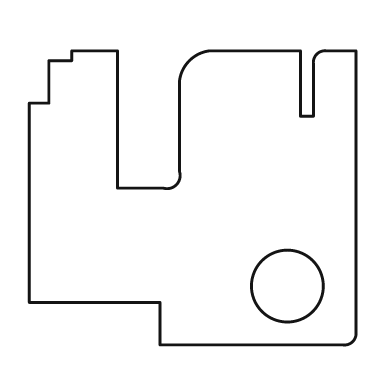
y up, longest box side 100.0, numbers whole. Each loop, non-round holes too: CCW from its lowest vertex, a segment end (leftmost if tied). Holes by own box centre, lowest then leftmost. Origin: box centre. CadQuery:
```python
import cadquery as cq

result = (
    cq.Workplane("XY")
    .moveTo(-10.0, -45.0)
    .lineTo(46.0, -45.0)
    .threePointArc((49.0, -44.0), (50.0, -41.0))
    .lineTo(50.0, 45.0)
    .lineTo(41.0, 45.0)
    .threePointArc((38.0, 44.0), (37.0, 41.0))
    .lineTo(37.0, 25.0)
    .lineTo(33.0, 25.0)
    .lineTo(33.0, 45.0)
    .lineTo(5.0, 45.0)
    .threePointArc((-1.0, 42.0), (-4.0, 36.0))
    .lineTo(-4.0, 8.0)
    .threePointArc((-5.0, 4.0), (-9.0, 3.0))
    .lineTo(-23.0, 3.0)
    .lineTo(-23.0, 45.0)
    .lineTo(-37.0, 45.0)
    .lineTo(-37.0, 42.0)
    .lineTo(-44.0, 42.0)
    .lineTo(-44.0, 29.0)
    .lineTo(-50.0, 29.0)
    .lineTo(-50.0, -32.0)
    .lineTo(-10.0, -32.0)
    .close()
    .moveTo(29.0, -27.0)
    .circle(11.0)
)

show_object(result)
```